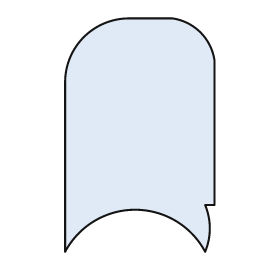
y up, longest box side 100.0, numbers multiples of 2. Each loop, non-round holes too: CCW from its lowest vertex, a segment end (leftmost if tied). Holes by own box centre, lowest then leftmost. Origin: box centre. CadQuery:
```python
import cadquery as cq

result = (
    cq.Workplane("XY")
    .moveTo(-32.0, -50.0)
    .threePointArc((-2.0, -32.0), (28.0, -50.0))
    .threePointArc((30.0, -40.0), (28.0, -30.0))
    .lineTo(32.0, -30.0)
    .lineTo(32.0, 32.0)
    .threePointArc((26.0, 44.0), (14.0, 50.0))
    .lineTo(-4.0, 50.0)
    .threePointArc((-24.0, 42.0), (-32.0, 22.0))
    .close()
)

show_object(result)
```